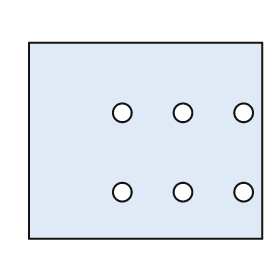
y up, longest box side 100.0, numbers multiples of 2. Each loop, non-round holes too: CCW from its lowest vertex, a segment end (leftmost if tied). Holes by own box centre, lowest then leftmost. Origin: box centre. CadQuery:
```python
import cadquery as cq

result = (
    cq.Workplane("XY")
    .moveTo(-50.0, -42.0)
    .lineTo(50.0, -42.0)
    .lineTo(50.0, 42.0)
    .lineTo(-50.0, 42.0)
    .close()
    .moveTo(-10.0, -22.0)
    .circle(4.0)
    .moveTo(16.0, -22.0)
    .circle(4.0)
    .moveTo(42.0, -22.0)
    .circle(4.0)
    .moveTo(-10.0, 12.0)
    .circle(4.0)
    .moveTo(16.0, 12.0)
    .circle(4.0)
    .moveTo(42.0, 12.0)
    .circle(4.0)
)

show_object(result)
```